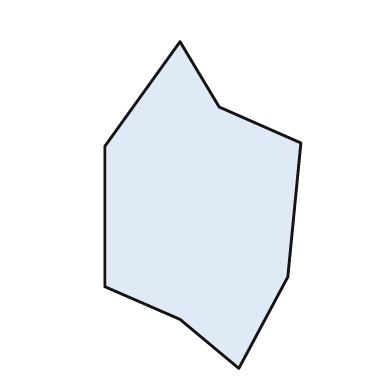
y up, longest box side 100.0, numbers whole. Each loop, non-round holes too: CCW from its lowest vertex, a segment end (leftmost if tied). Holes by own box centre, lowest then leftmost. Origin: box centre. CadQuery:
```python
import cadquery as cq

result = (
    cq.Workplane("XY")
    .moveTo(11.0, -50.0)
    .lineTo(26.0, -22.0)
    .lineTo(30.0, 19.0)
    .lineTo(5.0, 30.0)
    .lineTo(-7.0, 50.0)
    .lineTo(-30.0, 18.0)
    .lineTo(-30.0, -25.0)
    .lineTo(-7.0, -35.0)
    .close()
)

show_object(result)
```